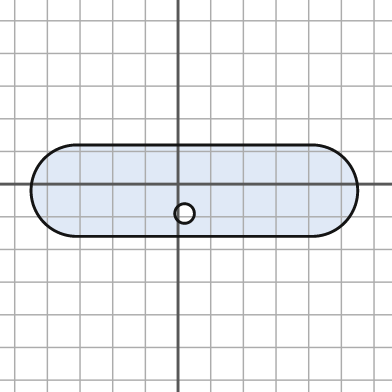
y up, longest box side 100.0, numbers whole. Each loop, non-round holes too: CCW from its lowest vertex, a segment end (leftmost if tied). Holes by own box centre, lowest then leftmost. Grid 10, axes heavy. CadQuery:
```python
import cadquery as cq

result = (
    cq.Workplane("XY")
    .moveTo(-31.0, -16.0)
    .lineTo(41.0, -16.0)
    .threePointArc((55.0, -2.0), (41.0, 12.0))
    .lineTo(-31.0, 12.0)
    .threePointArc((-45.0, -2.0), (-31.0, -16.0))
    .close()
    .moveTo(2.0, -9.0)
    .circle(3.0)
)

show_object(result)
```